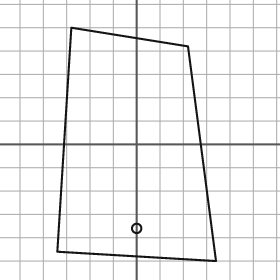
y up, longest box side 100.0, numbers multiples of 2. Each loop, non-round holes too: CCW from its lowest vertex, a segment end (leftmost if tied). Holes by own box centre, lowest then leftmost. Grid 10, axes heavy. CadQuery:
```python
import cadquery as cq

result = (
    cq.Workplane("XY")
    .moveTo(34.0, -50.0)
    .lineTo(22.0, 42.0)
    .lineTo(-28.0, 50.0)
    .lineTo(-34.0, -46.0)
    .close()
    .moveTo(0.0, -36.0)
    .circle(2.0)
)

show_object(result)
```